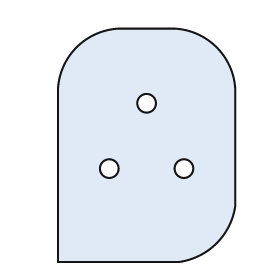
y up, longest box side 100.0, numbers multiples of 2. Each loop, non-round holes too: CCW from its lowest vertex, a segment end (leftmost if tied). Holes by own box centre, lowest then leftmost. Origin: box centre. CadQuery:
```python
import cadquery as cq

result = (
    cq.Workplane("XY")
    .moveTo(-38.0, -50.0)
    .lineTo(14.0, -50.0)
    .threePointArc((30.0, -42.0), (38.0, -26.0))
    .lineTo(38.0, 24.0)
    .threePointArc((30.0, 42.0), (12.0, 50.0))
    .lineTo(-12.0, 50.0)
    .threePointArc((-30.0, 42.0), (-38.0, 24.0))
    .close()
    .moveTo(-16.0, -10.0)
    .circle(4.0)
    .moveTo(16.0, -10.0)
    .circle(4.0)
    .moveTo(0.0, 18.0)
    .circle(4.0)
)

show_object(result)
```